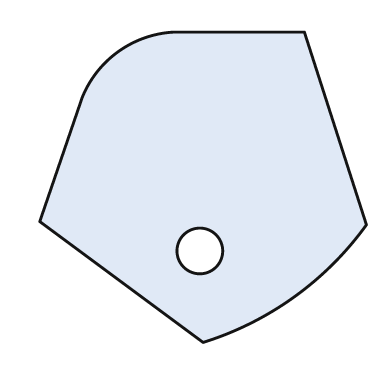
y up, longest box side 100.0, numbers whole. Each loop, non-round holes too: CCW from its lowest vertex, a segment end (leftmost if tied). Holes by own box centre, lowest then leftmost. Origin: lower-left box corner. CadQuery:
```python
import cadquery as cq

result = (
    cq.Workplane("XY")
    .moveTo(50.0, 0.0)
    .threePointArc((78.0, 14.0), (100.0, 36.0))
    .lineTo(81.0, 95.0)
    .lineTo(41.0, 95.0)
    .threePointArc((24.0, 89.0), (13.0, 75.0))
    .lineTo(0.0, 37.0)
    .close()
    .moveTo(49.0, 28.0)
    .circle(7.0)
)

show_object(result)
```